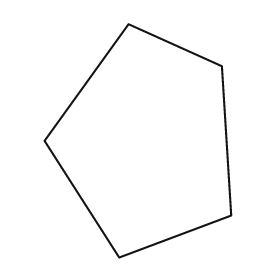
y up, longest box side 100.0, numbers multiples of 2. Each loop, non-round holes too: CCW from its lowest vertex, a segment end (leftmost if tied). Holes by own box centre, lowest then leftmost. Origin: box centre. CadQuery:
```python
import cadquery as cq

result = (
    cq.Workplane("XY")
    .moveTo(-8.0, -50.0)
    .lineTo(40.0, -32.0)
    .lineTo(36.0, 32.0)
    .lineTo(-4.0, 50.0)
    .lineTo(-40.0, 0.0)
    .close()
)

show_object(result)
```